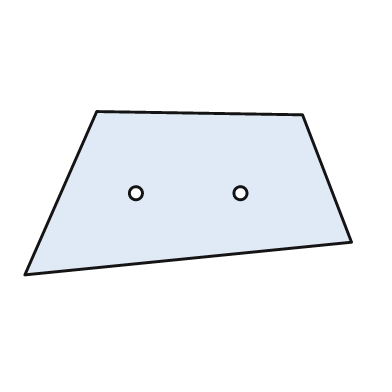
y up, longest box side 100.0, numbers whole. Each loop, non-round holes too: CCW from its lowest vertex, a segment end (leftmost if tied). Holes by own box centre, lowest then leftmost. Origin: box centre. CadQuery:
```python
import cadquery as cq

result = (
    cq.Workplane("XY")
    .moveTo(-50.0, -25.0)
    .lineTo(50.0, -15.0)
    .lineTo(35.0, 24.0)
    .lineTo(-28.0, 25.0)
    .close()
    .moveTo(-16.0, 0.0)
    .circle(2.0)
    .moveTo(16.0, 0.0)
    .circle(2.0)
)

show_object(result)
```